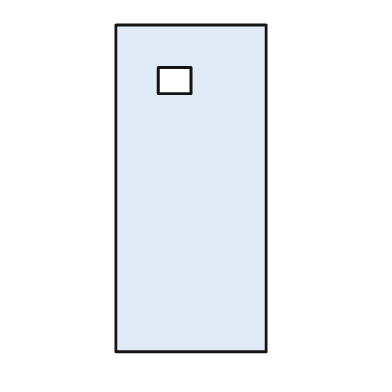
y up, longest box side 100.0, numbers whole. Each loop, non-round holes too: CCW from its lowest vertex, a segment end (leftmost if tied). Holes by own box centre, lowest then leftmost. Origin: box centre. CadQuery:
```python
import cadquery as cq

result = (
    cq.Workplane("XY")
    .moveTo(-23.0, -50.0)
    .lineTo(23.0, -50.0)
    .lineTo(23.0, 50.0)
    .lineTo(-23.0, 50.0)
    .close()
    .moveTo(-10.0, 29.0)
    .lineTo(0.0, 29.0)
    .lineTo(0.0, 37.0)
    .lineTo(-10.0, 37.0)
    .close()
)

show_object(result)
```